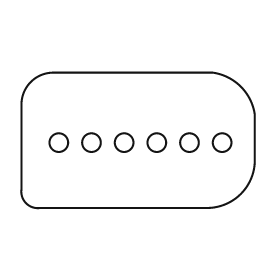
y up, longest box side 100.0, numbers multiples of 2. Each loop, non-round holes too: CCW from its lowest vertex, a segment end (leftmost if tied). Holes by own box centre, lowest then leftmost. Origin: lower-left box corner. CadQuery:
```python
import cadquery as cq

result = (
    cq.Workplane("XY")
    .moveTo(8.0, 0.0)
    .lineTo(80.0, 0.0)
    .threePointArc((94.0, 6.0), (100.0, 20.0))
    .lineTo(100.0, 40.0)
    .threePointArc((94.0, 52.0), (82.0, 58.0))
    .lineTo(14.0, 58.0)
    .threePointArc((4.0, 54.0), (0.0, 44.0))
    .lineTo(0.0, 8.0)
    .threePointArc((2.0, 2.0), (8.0, 0.0))
    .close()
    .moveTo(16.0, 28.0)
    .circle(4.0)
    .moveTo(30.0, 28.0)
    .circle(4.0)
    .moveTo(44.0, 28.0)
    .circle(4.0)
    .moveTo(58.0, 28.0)
    .circle(4.0)
    .moveTo(72.0, 28.0)
    .circle(4.0)
    .moveTo(86.0, 28.0)
    .circle(4.0)
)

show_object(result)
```